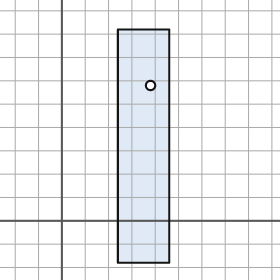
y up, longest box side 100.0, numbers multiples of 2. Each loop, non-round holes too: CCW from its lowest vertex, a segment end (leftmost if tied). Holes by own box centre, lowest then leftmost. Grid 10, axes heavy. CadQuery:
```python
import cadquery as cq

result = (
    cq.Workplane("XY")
    .moveTo(24.0, -18.0)
    .lineTo(46.0, -18.0)
    .lineTo(46.0, 82.0)
    .lineTo(24.0, 82.0)
    .close()
    .moveTo(38.0, 58.0)
    .circle(2.0)
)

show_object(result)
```